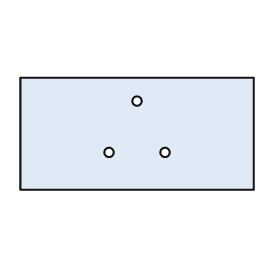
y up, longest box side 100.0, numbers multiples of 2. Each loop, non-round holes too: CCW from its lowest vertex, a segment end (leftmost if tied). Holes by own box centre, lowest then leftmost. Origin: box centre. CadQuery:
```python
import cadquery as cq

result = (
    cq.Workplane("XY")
    .moveTo(-50.0, -24.0)
    .lineTo(50.0, -24.0)
    .lineTo(50.0, 24.0)
    .lineTo(-50.0, 24.0)
    .close()
    .moveTo(-12.0, -8.0)
    .circle(2.0)
    .moveTo(12.0, -8.0)
    .circle(2.0)
    .moveTo(0.0, 14.0)
    .circle(2.0)
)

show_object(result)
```